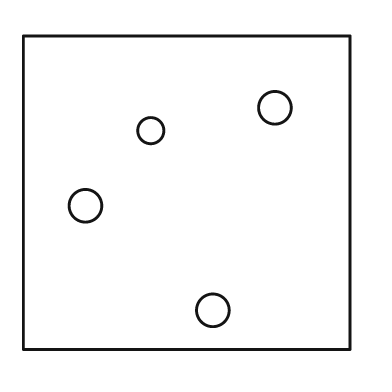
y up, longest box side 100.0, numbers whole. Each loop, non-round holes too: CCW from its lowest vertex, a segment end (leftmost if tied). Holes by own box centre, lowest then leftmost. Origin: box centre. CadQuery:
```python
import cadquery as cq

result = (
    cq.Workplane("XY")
    .moveTo(-50.0, -48.0)
    .lineTo(50.0, -48.0)
    .lineTo(50.0, 48.0)
    .lineTo(-50.0, 48.0)
    .close()
    .moveTo(8.0, -36.0)
    .circle(5.0)
    .moveTo(-31.0, -4.0)
    .circle(5.0)
    .moveTo(-11.0, 19.0)
    .circle(4.0)
    .moveTo(27.0, 26.0)
    .circle(5.0)
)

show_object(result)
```